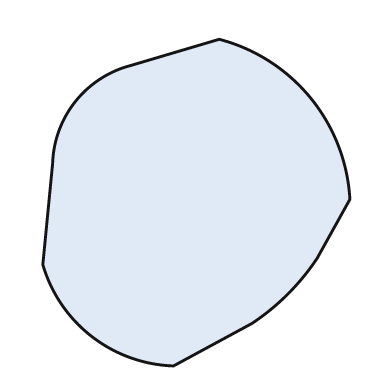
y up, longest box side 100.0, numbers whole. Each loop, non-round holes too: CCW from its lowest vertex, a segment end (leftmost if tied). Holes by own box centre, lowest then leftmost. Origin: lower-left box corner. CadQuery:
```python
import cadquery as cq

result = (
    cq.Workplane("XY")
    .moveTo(40.0, 0.0)
    .lineTo(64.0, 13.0)
    .threePointArc((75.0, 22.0), (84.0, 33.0))
    .lineTo(94.0, 51.0)
    .threePointArc((82.0, 82.0), (54.0, 100.0))
    .lineTo(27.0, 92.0)
    .threePointArc((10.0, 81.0), (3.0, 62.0))
    .lineTo(0.0, 31.0)
    .threePointArc((15.0, 9.0), (40.0, 0.0))
    .close()
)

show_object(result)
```